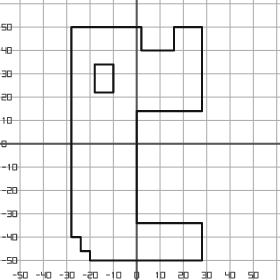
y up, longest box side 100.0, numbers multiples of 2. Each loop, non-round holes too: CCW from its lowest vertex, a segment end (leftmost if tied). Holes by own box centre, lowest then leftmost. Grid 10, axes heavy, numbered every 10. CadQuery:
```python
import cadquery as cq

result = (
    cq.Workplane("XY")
    .moveTo(-20.0, -50.0)
    .lineTo(28.0, -50.0)
    .lineTo(28.0, -34.0)
    .lineTo(0.0, -34.0)
    .lineTo(0.0, 14.0)
    .lineTo(28.0, 14.0)
    .lineTo(28.0, 50.0)
    .lineTo(16.0, 50.0)
    .lineTo(16.0, 40.0)
    .lineTo(2.0, 40.0)
    .lineTo(2.0, 50.0)
    .lineTo(-28.0, 50.0)
    .lineTo(-28.0, -40.0)
    .lineTo(-24.0, -40.0)
    .lineTo(-24.0, -46.0)
    .lineTo(-20.0, -46.0)
    .close()
    .moveTo(-18.0, 22.0)
    .lineTo(-10.0, 22.0)
    .lineTo(-10.0, 34.0)
    .lineTo(-18.0, 34.0)
    .close()
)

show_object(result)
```